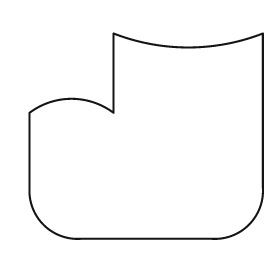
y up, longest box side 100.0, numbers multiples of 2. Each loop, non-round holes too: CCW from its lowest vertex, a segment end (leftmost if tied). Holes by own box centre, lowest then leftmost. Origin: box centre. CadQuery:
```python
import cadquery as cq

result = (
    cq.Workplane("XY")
    .moveTo(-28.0, -44.0)
    .lineTo(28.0, -44.0)
    .threePointArc((44.0, -38.0), (50.0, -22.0))
    .lineTo(50.0, 44.0)
    .threePointArc((18.0, 38.0), (-14.0, 44.0))
    .lineTo(-14.0, 10.0)
    .threePointArc((-32.0, 16.0), (-50.0, 10.0))
    .lineTo(-50.0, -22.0)
    .threePointArc((-44.0, -38.0), (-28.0, -44.0))
    .close()
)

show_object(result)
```